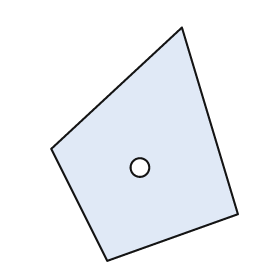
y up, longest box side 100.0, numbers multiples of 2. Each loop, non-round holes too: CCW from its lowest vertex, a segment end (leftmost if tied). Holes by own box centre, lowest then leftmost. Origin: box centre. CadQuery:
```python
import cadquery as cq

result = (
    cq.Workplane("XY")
    .moveTo(-16.0, -50.0)
    .lineTo(40.0, -30.0)
    .lineTo(16.0, 50.0)
    .lineTo(-40.0, -2.0)
    .close()
    .moveTo(-2.0, -10.0)
    .circle(4.0)
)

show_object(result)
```